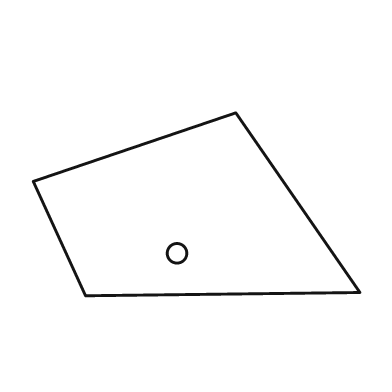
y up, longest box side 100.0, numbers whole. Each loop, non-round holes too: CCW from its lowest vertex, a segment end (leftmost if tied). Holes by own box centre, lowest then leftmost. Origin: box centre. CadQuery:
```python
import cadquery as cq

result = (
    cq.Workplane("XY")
    .moveTo(-34.0, -28.0)
    .lineTo(50.0, -27.0)
    .lineTo(12.0, 28.0)
    .lineTo(-50.0, 7.0)
    .close()
    .moveTo(-6.0, -15.0)
    .circle(3.0)
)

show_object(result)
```